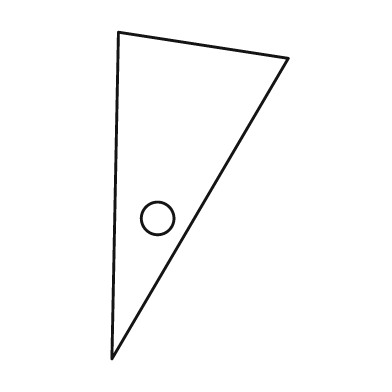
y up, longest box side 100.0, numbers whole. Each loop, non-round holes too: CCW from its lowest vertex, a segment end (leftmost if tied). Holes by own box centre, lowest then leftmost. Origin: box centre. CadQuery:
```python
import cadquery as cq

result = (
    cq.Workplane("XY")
    .moveTo(-27.0, -50.0)
    .lineTo(27.0, 42.0)
    .lineTo(-25.0, 50.0)
    .close()
    .moveTo(-13.0, -7.0)
    .circle(5.0)
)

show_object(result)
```